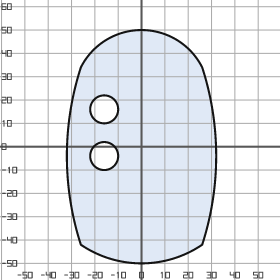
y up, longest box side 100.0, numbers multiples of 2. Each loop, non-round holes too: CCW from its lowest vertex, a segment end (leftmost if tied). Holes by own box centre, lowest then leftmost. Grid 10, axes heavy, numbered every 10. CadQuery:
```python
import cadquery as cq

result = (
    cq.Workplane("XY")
    .moveTo(-26.0, -42.0)
    .threePointArc((0.0, -50.0), (26.0, -42.0))
    .threePointArc((32.0, -4.0), (26.0, 34.0))
    .threePointArc((0.0, 50.0), (-26.0, 34.0))
    .threePointArc((-32.0, -4.0), (-26.0, -42.0))
    .close()
    .moveTo(-16.0, -4.0)
    .circle(6.0)
    .moveTo(-16.0, 16.0)
    .circle(6.0)
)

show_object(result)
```